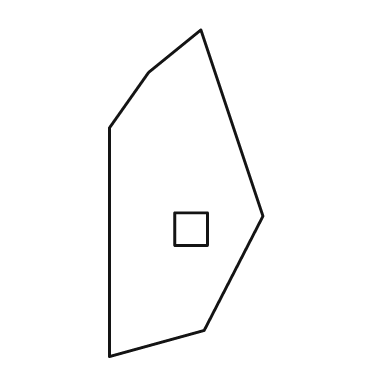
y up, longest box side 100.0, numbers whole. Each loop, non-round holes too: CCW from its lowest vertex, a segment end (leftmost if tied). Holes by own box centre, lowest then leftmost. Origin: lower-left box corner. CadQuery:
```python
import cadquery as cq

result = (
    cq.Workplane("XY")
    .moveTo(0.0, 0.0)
    .lineTo(29.0, 8.0)
    .lineTo(47.0, 43.0)
    .lineTo(28.0, 100.0)
    .lineTo(12.0, 87.0)
    .lineTo(0.0, 70.0)
    .close()
    .moveTo(20.0, 34.0)
    .lineTo(30.0, 34.0)
    .lineTo(30.0, 44.0)
    .lineTo(20.0, 44.0)
    .close()
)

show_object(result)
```